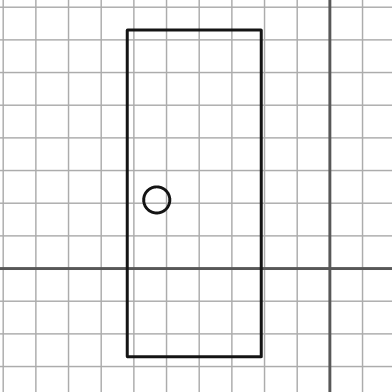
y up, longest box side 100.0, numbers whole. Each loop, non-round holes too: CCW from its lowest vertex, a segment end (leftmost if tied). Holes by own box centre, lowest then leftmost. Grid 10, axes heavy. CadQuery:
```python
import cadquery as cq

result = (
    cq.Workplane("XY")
    .moveTo(-62.0, -27.0)
    .lineTo(-21.0, -27.0)
    .lineTo(-21.0, 73.0)
    .lineTo(-62.0, 73.0)
    .close()
    .moveTo(-53.0, 21.0)
    .circle(4.0)
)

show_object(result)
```